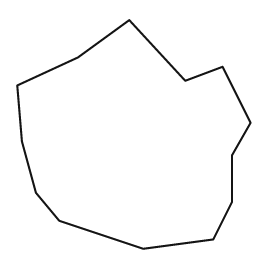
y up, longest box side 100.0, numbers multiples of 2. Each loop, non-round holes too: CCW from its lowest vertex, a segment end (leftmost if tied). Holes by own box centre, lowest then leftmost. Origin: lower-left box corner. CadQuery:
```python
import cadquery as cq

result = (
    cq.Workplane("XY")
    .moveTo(54.0, 0.0)
    .lineTo(84.0, 4.0)
    .lineTo(92.0, 20.0)
    .lineTo(92.0, 40.0)
    .lineTo(100.0, 54.0)
    .lineTo(88.0, 78.0)
    .lineTo(72.0, 72.0)
    .lineTo(48.0, 98.0)
    .lineTo(26.0, 82.0)
    .lineTo(0.0, 70.0)
    .lineTo(2.0, 46.0)
    .lineTo(8.0, 24.0)
    .lineTo(18.0, 12.0)
    .close()
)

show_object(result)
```